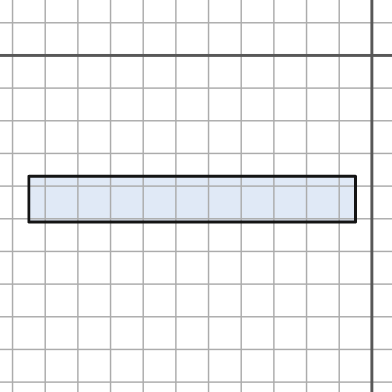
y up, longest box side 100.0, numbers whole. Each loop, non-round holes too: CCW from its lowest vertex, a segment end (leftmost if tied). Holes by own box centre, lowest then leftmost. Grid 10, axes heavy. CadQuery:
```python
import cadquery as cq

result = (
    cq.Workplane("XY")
    .moveTo(-105.0, -51.0)
    .lineTo(-5.0, -51.0)
    .lineTo(-5.0, -37.0)
    .lineTo(-105.0, -37.0)
    .close()
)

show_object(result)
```